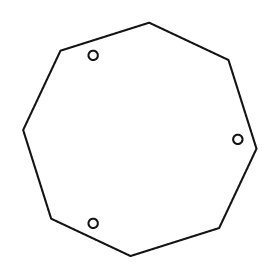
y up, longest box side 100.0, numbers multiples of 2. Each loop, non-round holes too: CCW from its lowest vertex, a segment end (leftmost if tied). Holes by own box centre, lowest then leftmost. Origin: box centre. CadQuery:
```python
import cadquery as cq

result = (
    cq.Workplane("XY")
    .moveTo(-4.0, -50.0)
    .lineTo(34.0, -38.0)
    .lineTo(50.0, -4.0)
    .lineTo(38.0, 34.0)
    .lineTo(4.0, 50.0)
    .lineTo(-34.0, 38.0)
    .lineTo(-50.0, 4.0)
    .lineTo(-38.0, -34.0)
    .close()
    .moveTo(-20.0, -36.0)
    .circle(2.0)
    .moveTo(42.0, 0.0)
    .circle(2.0)
    .moveTo(-20.0, 36.0)
    .circle(2.0)
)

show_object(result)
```